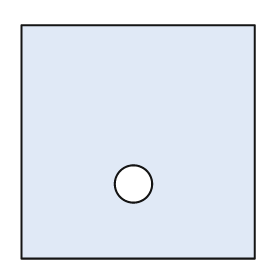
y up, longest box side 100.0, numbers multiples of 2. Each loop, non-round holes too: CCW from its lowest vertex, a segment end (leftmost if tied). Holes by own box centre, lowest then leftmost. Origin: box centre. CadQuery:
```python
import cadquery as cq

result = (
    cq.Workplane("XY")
    .moveTo(-50.0, -50.0)
    .lineTo(50.0, -50.0)
    .lineTo(50.0, 50.0)
    .lineTo(-50.0, 50.0)
    .close()
    .moveTo(-2.0, -18.0)
    .circle(8.0)
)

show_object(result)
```